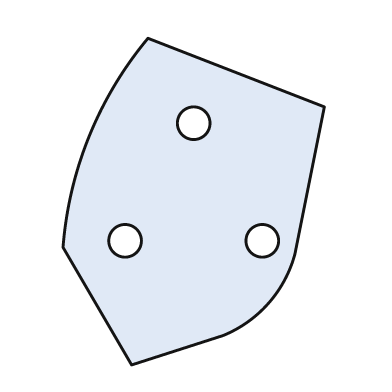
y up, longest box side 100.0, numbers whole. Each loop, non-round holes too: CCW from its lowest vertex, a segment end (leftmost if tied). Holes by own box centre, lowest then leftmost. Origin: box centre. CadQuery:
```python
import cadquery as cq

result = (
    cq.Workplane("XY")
    .moveTo(-19.0, -50.0)
    .lineTo(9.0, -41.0)
    .threePointArc((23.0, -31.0), (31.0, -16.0))
    .lineTo(40.0, 29.0)
    .lineTo(-14.0, 50.0)
    .threePointArc((-32.0, 20.0), (-40.0, -14.0))
    .close()
    .moveTo(-21.0, -12.0)
    .circle(5.0)
    .moveTo(21.0, -12.0)
    .circle(5.0)
    .moveTo(0.0, 24.0)
    .circle(5.0)
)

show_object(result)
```